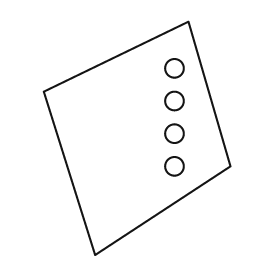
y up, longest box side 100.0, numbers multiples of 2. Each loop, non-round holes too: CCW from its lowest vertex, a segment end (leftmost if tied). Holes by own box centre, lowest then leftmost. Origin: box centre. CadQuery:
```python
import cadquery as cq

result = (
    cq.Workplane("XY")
    .moveTo(-18.0, -50.0)
    .lineTo(40.0, -12.0)
    .lineTo(22.0, 50.0)
    .lineTo(-40.0, 20.0)
    .close()
    .moveTo(16.0, -12.0)
    .circle(4.0)
    .moveTo(16.0, 2.0)
    .circle(4.0)
    .moveTo(16.0, 16.0)
    .circle(4.0)
    .moveTo(16.0, 30.0)
    .circle(4.0)
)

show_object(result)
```